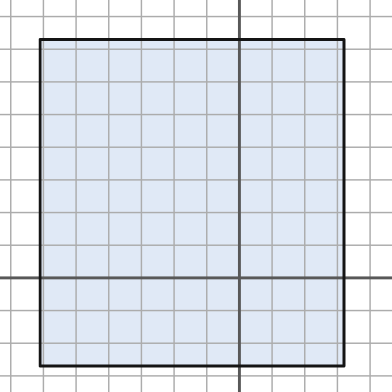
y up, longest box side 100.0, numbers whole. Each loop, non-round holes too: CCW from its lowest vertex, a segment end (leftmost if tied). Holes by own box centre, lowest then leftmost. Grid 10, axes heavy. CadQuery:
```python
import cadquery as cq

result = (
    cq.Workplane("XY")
    .moveTo(-61.0, -27.0)
    .lineTo(32.0, -27.0)
    .lineTo(32.0, 73.0)
    .lineTo(-61.0, 73.0)
    .close()
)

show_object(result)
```